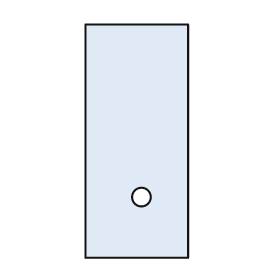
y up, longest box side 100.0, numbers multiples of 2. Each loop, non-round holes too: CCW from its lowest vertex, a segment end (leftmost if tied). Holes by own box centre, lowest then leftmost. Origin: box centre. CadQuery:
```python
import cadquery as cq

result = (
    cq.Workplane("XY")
    .moveTo(-22.0, -50.0)
    .lineTo(22.0, -50.0)
    .lineTo(22.0, 50.0)
    .lineTo(-22.0, 50.0)
    .close()
    .moveTo(2.0, -24.0)
    .circle(4.0)
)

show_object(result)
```